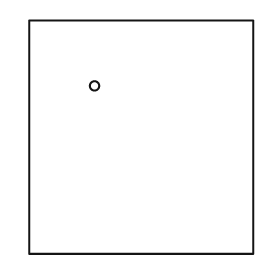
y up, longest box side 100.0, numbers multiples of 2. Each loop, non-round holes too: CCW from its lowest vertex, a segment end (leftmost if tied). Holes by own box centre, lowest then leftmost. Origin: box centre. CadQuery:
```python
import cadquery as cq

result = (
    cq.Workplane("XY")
    .moveTo(-48.0, -50.0)
    .lineTo(48.0, -50.0)
    .lineTo(48.0, 50.0)
    .lineTo(-48.0, 50.0)
    .close()
    .moveTo(-20.0, 22.0)
    .circle(2.0)
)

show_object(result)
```